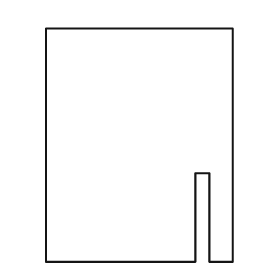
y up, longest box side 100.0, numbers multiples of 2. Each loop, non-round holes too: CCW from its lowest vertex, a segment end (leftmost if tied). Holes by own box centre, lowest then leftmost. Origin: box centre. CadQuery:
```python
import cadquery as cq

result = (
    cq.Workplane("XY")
    .moveTo(-40.0, -50.0)
    .lineTo(24.0, -50.0)
    .lineTo(24.0, -12.0)
    .lineTo(30.0, -12.0)
    .lineTo(30.0, -50.0)
    .lineTo(40.0, -50.0)
    .lineTo(40.0, 50.0)
    .lineTo(-40.0, 50.0)
    .close()
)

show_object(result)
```